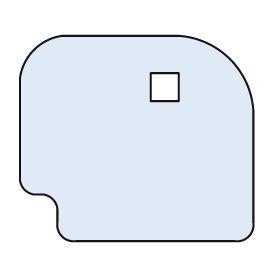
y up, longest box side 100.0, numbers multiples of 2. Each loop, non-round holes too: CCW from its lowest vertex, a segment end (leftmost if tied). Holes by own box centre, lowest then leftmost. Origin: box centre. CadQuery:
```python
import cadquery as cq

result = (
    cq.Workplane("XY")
    .moveTo(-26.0, -44.0)
    .lineTo(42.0, -44.0)
    .threePointArc((48.0, -42.0), (50.0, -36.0))
    .lineTo(50.0, 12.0)
    .threePointArc((40.0, 34.0), (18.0, 44.0))
    .lineTo(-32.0, 44.0)
    .threePointArc((-44.0, 38.0), (-50.0, 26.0))
    .lineTo(-50.0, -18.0)
    .threePointArc((-48.0, -22.0), (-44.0, -24.0))
    .lineTo(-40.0, -24.0)
    .threePointArc((-36.0, -26.0), (-34.0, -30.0))
    .lineTo(-34.0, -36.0)
    .threePointArc((-32.0, -42.0), (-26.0, -44.0))
    .close()
    .moveTo(6.0, 16.0)
    .lineTo(18.0, 16.0)
    .lineTo(18.0, 28.0)
    .lineTo(6.0, 28.0)
    .close()
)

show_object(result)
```